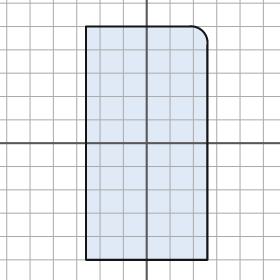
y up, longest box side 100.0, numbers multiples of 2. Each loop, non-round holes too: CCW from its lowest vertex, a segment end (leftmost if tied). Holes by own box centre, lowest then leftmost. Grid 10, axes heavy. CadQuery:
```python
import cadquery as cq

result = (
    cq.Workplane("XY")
    .moveTo(-26.0, -50.0)
    .lineTo(26.0, -50.0)
    .lineTo(26.0, 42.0)
    .threePointArc((24.0, 48.0), (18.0, 50.0))
    .lineTo(-26.0, 50.0)
    .close()
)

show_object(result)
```